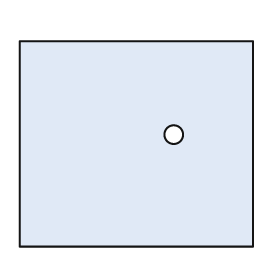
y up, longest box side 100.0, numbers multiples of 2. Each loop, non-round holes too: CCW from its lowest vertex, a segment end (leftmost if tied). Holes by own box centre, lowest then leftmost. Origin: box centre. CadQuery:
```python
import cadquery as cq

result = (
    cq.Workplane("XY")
    .moveTo(-50.0, -44.0)
    .lineTo(50.0, -44.0)
    .lineTo(50.0, 44.0)
    .lineTo(-50.0, 44.0)
    .close()
    .moveTo(16.0, 4.0)
    .circle(4.0)
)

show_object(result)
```